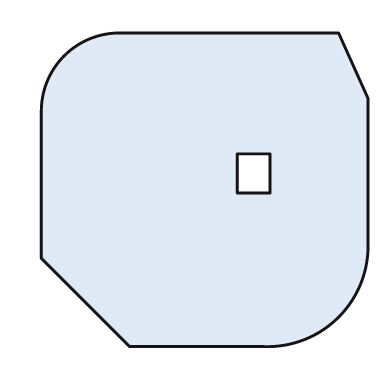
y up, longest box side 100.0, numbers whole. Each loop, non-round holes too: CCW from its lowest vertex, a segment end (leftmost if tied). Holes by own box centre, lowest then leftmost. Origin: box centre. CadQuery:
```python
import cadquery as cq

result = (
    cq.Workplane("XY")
    .moveTo(-23.0, -48.0)
    .lineTo(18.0, -48.0)
    .threePointArc((41.0, -39.0), (50.0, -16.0))
    .lineTo(50.0, 28.0)
    .lineTo(41.0, 48.0)
    .lineTo(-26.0, 48.0)
    .threePointArc((-43.0, 41.0), (-50.0, 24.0))
    .lineTo(-50.0, -21.0)
    .close()
    .moveTo(10.0, -1.0)
    .lineTo(20.0, -1.0)
    .lineTo(20.0, 11.0)
    .lineTo(10.0, 11.0)
    .close()
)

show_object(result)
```